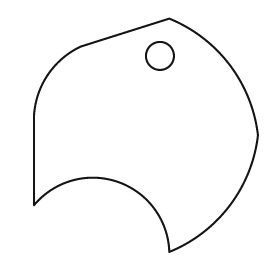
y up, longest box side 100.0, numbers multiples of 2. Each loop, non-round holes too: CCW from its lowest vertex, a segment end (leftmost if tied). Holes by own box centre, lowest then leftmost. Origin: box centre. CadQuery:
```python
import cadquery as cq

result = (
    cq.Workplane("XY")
    .moveTo(10.0, -50.0)
    .threePointArc((36.0, -30.0), (48.0, 0.0))
    .threePointArc((36.0, 30.0), (10.0, 50.0))
    .lineTo(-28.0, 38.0)
    .threePointArc((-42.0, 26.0), (-48.0, 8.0))
    .lineTo(-48.0, -30.0)
    .threePointArc((-12.0, -20.0), (10.0, -50.0))
    .close()
    .moveTo(6.0, 34.0)
    .circle(6.0)
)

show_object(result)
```